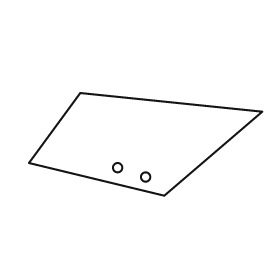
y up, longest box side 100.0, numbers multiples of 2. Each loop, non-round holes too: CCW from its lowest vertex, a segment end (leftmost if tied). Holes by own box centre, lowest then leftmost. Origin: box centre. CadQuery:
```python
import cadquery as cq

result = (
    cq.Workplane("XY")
    .moveTo(8.0, -22.0)
    .lineTo(50.0, 14.0)
    .lineTo(-28.0, 22.0)
    .lineTo(-50.0, -8.0)
    .close()
    .moveTo(0.0, -14.0)
    .circle(2.0)
    .moveTo(-12.0, -10.0)
    .circle(2.0)
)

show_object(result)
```